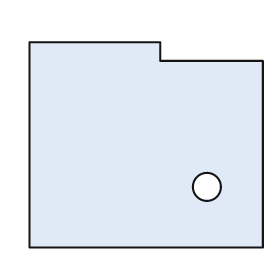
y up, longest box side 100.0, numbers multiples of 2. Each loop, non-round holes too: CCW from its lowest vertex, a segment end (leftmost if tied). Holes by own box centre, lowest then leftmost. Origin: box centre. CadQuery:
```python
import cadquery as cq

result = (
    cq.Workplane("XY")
    .moveTo(-50.0, -44.0)
    .lineTo(50.0, -44.0)
    .lineTo(50.0, 36.0)
    .lineTo(6.0, 36.0)
    .lineTo(6.0, 44.0)
    .lineTo(-50.0, 44.0)
    .close()
    .moveTo(26.0, -18.0)
    .circle(6.0)
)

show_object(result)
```